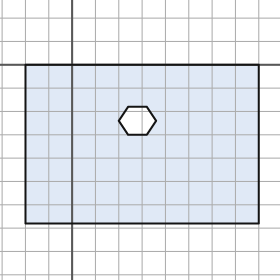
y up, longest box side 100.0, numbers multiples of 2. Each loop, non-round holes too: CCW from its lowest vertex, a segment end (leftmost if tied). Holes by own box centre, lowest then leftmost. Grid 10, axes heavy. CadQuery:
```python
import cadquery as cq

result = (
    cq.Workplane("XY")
    .moveTo(-20.0, -68.0)
    .lineTo(80.0, -68.0)
    .lineTo(80.0, 0.0)
    .lineTo(-20.0, 0.0)
    .close()
    .moveTo(24.0, -30.0)
    .lineTo(32.0, -30.0)
    .lineTo(36.0, -24.0)
    .lineTo(32.0, -18.0)
    .lineTo(24.0, -18.0)
    .lineTo(20.0, -24.0)
    .close()
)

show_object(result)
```